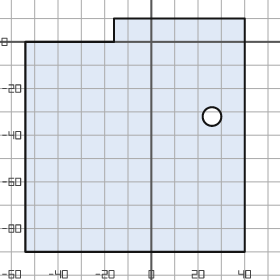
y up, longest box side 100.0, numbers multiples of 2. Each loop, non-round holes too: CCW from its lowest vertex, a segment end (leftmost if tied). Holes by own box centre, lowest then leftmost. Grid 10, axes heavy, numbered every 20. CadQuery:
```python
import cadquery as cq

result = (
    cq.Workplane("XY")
    .moveTo(-54.0, -90.0)
    .lineTo(40.0, -90.0)
    .lineTo(40.0, 10.0)
    .lineTo(-16.0, 10.0)
    .lineTo(-16.0, 0.0)
    .lineTo(-54.0, 0.0)
    .close()
    .moveTo(26.0, -32.0)
    .circle(4.0)
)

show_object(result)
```